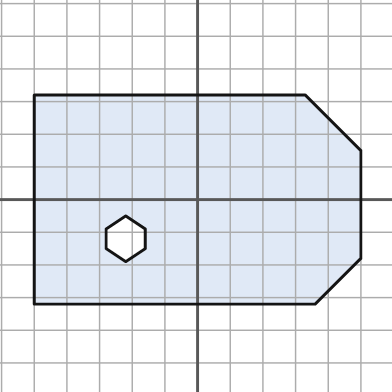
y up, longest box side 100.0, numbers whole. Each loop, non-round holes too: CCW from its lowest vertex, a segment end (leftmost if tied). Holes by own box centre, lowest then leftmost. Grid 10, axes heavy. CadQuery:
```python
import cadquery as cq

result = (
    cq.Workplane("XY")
    .moveTo(-50.0, -32.0)
    .lineTo(36.0, -32.0)
    .lineTo(50.0, -18.0)
    .lineTo(50.0, 15.0)
    .lineTo(33.0, 32.0)
    .lineTo(-50.0, 32.0)
    .close()
    .moveTo(-22.0, -19.0)
    .lineTo(-16.0, -15.0)
    .lineTo(-16.0, -9.0)
    .lineTo(-22.0, -5.0)
    .lineTo(-28.0, -9.0)
    .lineTo(-28.0, -15.0)
    .close()
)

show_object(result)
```